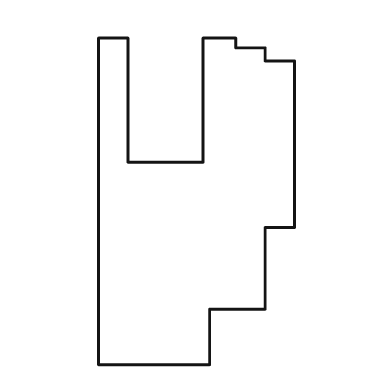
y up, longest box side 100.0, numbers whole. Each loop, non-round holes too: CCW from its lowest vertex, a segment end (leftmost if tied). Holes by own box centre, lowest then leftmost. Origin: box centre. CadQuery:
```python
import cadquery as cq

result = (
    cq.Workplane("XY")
    .moveTo(-30.0, -50.0)
    .lineTo(4.0, -50.0)
    .lineTo(4.0, -33.0)
    .lineTo(21.0, -33.0)
    .lineTo(21.0, -8.0)
    .lineTo(30.0, -8.0)
    .lineTo(30.0, 43.0)
    .lineTo(21.0, 43.0)
    .lineTo(21.0, 47.0)
    .lineTo(12.0, 47.0)
    .lineTo(12.0, 50.0)
    .lineTo(2.0, 50.0)
    .lineTo(2.0, 12.0)
    .lineTo(-21.0, 12.0)
    .lineTo(-21.0, 50.0)
    .lineTo(-30.0, 50.0)
    .close()
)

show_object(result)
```